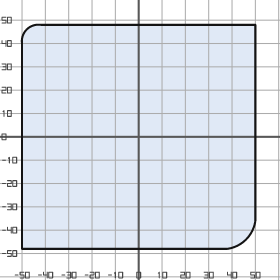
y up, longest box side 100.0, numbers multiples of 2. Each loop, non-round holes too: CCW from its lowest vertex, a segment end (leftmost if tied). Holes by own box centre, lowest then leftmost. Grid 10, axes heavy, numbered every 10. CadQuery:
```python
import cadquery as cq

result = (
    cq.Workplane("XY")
    .moveTo(-50.0, -48.0)
    .lineTo(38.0, -48.0)
    .threePointArc((46.0, -44.0), (50.0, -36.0))
    .lineTo(50.0, 48.0)
    .lineTo(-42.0, 48.0)
    .threePointArc((-48.0, 46.0), (-50.0, 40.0))
    .close()
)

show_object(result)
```